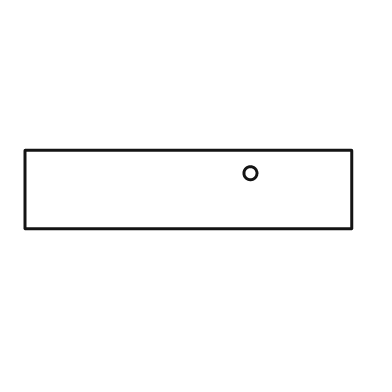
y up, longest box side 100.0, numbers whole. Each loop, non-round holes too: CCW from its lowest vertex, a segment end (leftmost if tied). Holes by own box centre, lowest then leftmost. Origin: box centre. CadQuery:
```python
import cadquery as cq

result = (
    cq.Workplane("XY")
    .moveTo(-50.0, -12.0)
    .lineTo(50.0, -12.0)
    .lineTo(50.0, 12.0)
    .lineTo(-50.0, 12.0)
    .close()
    .moveTo(19.0, 5.0)
    .circle(2.0)
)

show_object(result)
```